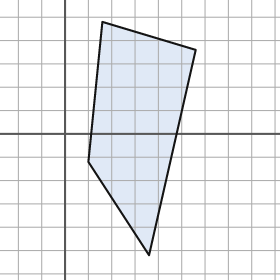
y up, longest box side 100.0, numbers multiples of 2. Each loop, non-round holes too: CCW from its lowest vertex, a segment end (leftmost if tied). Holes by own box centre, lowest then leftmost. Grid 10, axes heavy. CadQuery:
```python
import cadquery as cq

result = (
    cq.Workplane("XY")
    .moveTo(36.0, -52.0)
    .lineTo(56.0, 36.0)
    .lineTo(16.0, 48.0)
    .lineTo(10.0, -12.0)
    .close()
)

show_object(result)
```